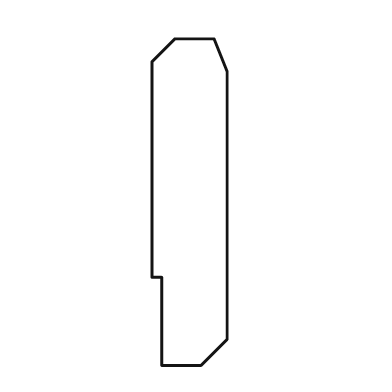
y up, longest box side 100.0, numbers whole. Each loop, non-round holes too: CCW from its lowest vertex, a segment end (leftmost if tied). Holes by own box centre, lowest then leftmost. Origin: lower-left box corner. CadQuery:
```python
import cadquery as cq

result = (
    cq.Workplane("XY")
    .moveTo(3.0, 0.0)
    .lineTo(15.0, 0.0)
    .lineTo(23.0, 8.0)
    .lineTo(23.0, 90.0)
    .lineTo(19.0, 100.0)
    .lineTo(7.0, 100.0)
    .lineTo(0.0, 93.0)
    .lineTo(0.0, 27.0)
    .lineTo(3.0, 27.0)
    .close()
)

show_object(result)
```